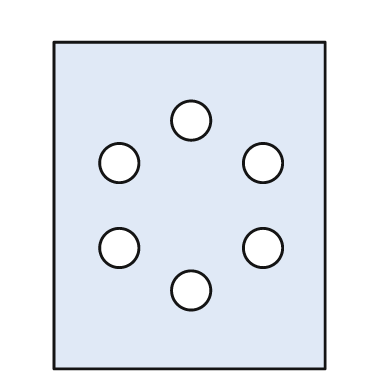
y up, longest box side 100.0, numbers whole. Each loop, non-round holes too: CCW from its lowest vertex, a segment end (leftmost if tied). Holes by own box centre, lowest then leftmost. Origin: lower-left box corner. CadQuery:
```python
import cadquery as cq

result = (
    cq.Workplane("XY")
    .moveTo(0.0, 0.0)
    .lineTo(83.0, 0.0)
    .lineTo(83.0, 100.0)
    .lineTo(0.0, 100.0)
    .close()
    .moveTo(42.0, 24.0)
    .circle(6.0)
    .moveTo(20.0, 37.0)
    .circle(6.0)
    .moveTo(64.0, 37.0)
    .circle(6.0)
    .moveTo(20.0, 63.0)
    .circle(6.0)
    .moveTo(64.0, 63.0)
    .circle(6.0)
    .moveTo(42.0, 76.0)
    .circle(6.0)
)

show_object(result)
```